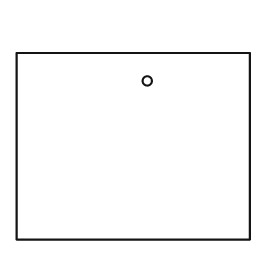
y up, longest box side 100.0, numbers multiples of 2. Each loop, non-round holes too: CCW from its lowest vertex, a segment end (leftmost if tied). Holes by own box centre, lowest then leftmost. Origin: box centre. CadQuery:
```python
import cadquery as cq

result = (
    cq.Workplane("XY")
    .moveTo(-50.0, -40.0)
    .lineTo(50.0, -40.0)
    .lineTo(50.0, 40.0)
    .lineTo(-50.0, 40.0)
    .close()
    .moveTo(6.0, 28.0)
    .circle(2.0)
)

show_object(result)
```